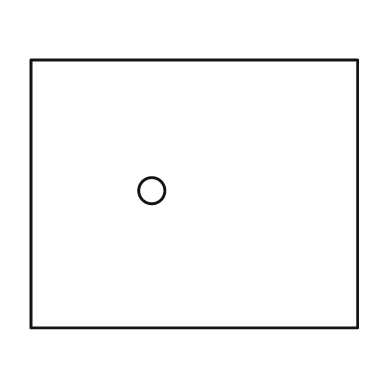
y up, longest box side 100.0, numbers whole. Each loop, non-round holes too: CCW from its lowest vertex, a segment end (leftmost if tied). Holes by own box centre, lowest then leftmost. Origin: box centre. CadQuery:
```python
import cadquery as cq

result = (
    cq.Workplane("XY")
    .moveTo(-50.0, -41.0)
    .lineTo(50.0, -41.0)
    .lineTo(50.0, 41.0)
    .lineTo(-50.0, 41.0)
    .close()
    .moveTo(-13.0, 1.0)
    .circle(4.0)
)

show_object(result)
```